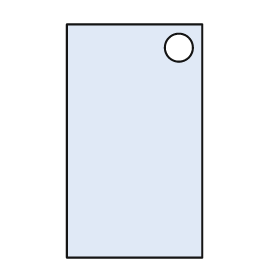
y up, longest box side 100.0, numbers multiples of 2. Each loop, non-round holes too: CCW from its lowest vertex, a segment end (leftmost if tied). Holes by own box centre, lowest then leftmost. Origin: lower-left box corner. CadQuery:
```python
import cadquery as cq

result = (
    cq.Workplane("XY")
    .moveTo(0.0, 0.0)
    .lineTo(58.0, 0.0)
    .lineTo(58.0, 100.0)
    .lineTo(0.0, 100.0)
    .close()
    .moveTo(48.0, 90.0)
    .circle(6.0)
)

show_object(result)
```